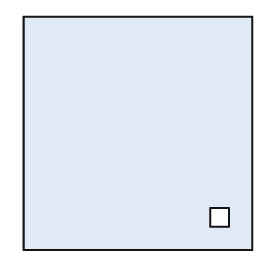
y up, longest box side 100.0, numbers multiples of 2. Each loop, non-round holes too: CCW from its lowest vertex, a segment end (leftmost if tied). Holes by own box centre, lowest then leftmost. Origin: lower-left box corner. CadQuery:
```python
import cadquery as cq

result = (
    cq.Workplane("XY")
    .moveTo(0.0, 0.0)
    .lineTo(98.0, 0.0)
    .lineTo(98.0, 100.0)
    .lineTo(0.0, 100.0)
    .close()
    .moveTo(80.0, 10.0)
    .lineTo(88.0, 10.0)
    .lineTo(88.0, 18.0)
    .lineTo(80.0, 18.0)
    .close()
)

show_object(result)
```